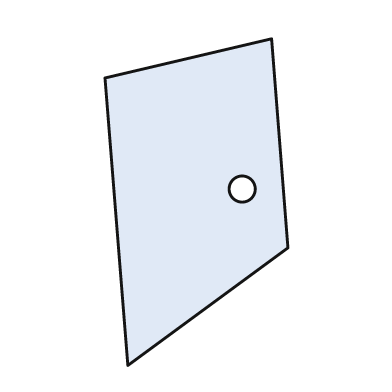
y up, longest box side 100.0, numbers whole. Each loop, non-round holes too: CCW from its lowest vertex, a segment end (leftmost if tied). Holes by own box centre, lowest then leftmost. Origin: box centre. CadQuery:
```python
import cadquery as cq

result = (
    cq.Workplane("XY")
    .moveTo(-21.0, -50.0)
    .lineTo(28.0, -14.0)
    .lineTo(23.0, 50.0)
    .lineTo(-28.0, 38.0)
    .close()
    .moveTo(14.0, 4.0)
    .circle(4.0)
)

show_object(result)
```